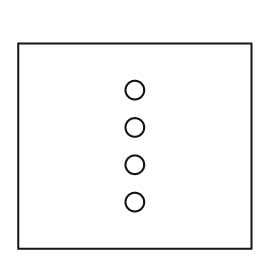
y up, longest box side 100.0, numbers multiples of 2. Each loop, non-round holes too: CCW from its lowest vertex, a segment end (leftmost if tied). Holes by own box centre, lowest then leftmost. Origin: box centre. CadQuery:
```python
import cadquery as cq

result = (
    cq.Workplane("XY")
    .moveTo(-50.0, -44.0)
    .lineTo(50.0, -44.0)
    .lineTo(50.0, 44.0)
    .lineTo(-50.0, 44.0)
    .close()
    .moveTo(0.0, -24.0)
    .circle(4.0)
    .moveTo(0.0, -8.0)
    .circle(4.0)
    .moveTo(0.0, 8.0)
    .circle(4.0)
    .moveTo(0.0, 24.0)
    .circle(4.0)
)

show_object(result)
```